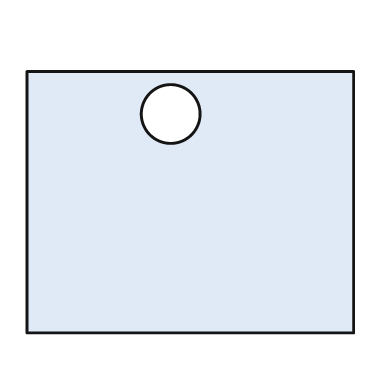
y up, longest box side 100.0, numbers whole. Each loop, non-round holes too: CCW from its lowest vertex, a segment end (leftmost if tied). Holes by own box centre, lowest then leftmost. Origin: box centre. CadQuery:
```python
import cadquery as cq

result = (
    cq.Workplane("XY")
    .moveTo(-50.0, -40.0)
    .lineTo(50.0, -40.0)
    .lineTo(50.0, 40.0)
    .lineTo(-50.0, 40.0)
    .close()
    .moveTo(-6.0, 27.0)
    .circle(9.0)
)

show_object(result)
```